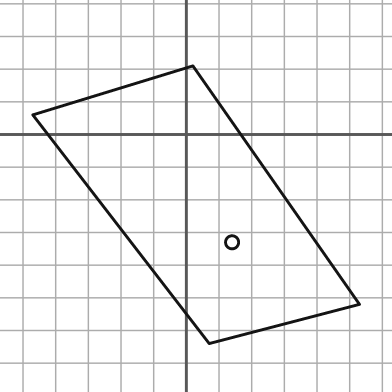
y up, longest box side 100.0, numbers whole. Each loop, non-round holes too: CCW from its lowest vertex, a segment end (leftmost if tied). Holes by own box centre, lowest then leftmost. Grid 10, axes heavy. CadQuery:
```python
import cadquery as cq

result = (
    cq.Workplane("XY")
    .moveTo(7.0, -64.0)
    .lineTo(53.0, -52.0)
    .lineTo(2.0, 21.0)
    .lineTo(-47.0, 6.0)
    .close()
    .moveTo(14.0, -33.0)
    .circle(2.0)
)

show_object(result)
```